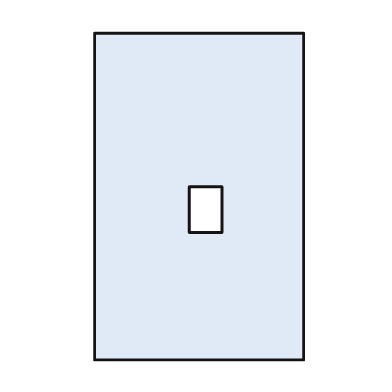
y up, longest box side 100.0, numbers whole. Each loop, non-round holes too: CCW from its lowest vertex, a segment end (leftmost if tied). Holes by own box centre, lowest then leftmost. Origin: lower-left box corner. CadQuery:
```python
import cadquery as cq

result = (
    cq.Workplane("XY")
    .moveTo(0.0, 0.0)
    .lineTo(64.0, 0.0)
    .lineTo(64.0, 100.0)
    .lineTo(0.0, 100.0)
    .close()
    .moveTo(29.0, 39.0)
    .lineTo(39.0, 39.0)
    .lineTo(39.0, 53.0)
    .lineTo(29.0, 53.0)
    .close()
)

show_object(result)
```